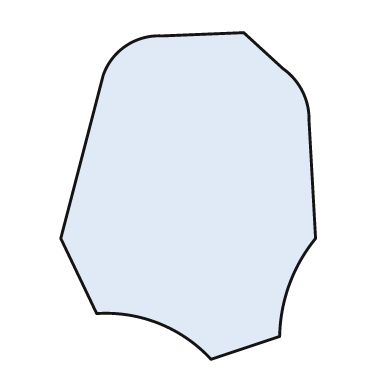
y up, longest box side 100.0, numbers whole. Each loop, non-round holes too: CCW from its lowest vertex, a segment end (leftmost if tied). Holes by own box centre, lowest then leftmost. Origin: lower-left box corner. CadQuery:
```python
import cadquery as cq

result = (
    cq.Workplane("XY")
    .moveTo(46.0, 0.0)
    .lineTo(67.0, 7.0)
    .threePointArc((70.0, 23.0), (78.0, 37.0))
    .lineTo(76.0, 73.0)
    .threePointArc((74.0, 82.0), (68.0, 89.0))
    .lineTo(56.0, 100.0)
    .lineTo(31.0, 99.0)
    .threePointArc((20.0, 96.0), (13.0, 87.0))
    .lineTo(0.0, 37.0)
    .lineTo(11.0, 14.0)
    .threePointArc((30.0, 11.0), (46.0, 0.0))
    .close()
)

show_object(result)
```